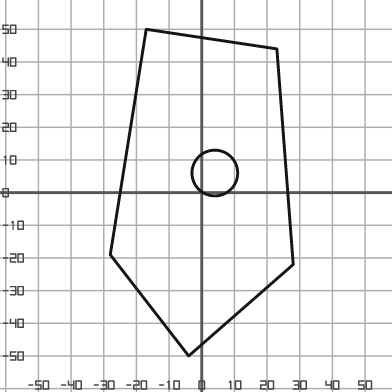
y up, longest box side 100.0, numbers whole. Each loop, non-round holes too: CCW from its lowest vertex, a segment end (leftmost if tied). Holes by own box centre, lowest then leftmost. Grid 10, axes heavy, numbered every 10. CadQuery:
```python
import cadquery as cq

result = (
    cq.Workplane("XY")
    .moveTo(-4.0, -50.0)
    .lineTo(28.0, -22.0)
    .lineTo(23.0, 44.0)
    .lineTo(-17.0, 50.0)
    .lineTo(-28.0, -19.0)
    .close()
    .moveTo(4.0, 6.0)
    .circle(7.0)
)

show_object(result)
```